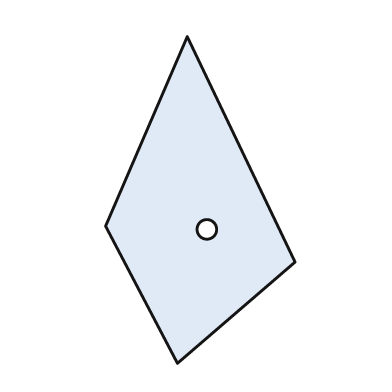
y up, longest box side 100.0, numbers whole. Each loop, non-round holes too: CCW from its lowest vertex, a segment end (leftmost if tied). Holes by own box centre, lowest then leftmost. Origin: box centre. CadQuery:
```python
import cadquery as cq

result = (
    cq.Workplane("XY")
    .moveTo(-7.0, -50.0)
    .lineTo(29.0, -19.0)
    .lineTo(-4.0, 50.0)
    .lineTo(-29.0, -8.0)
    .close()
    .moveTo(2.0, -9.0)
    .circle(3.0)
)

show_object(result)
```